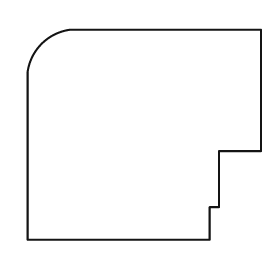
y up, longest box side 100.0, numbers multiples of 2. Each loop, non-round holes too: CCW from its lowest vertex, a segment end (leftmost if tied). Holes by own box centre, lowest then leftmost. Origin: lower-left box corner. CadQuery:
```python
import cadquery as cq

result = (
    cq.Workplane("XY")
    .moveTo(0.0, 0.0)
    .lineTo(78.0, 0.0)
    .lineTo(78.0, 14.0)
    .lineTo(82.0, 14.0)
    .lineTo(82.0, 38.0)
    .lineTo(100.0, 38.0)
    .lineTo(100.0, 90.0)
    .lineTo(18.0, 90.0)
    .threePointArc((6.0, 84.0), (0.0, 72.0))
    .close()
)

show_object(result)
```